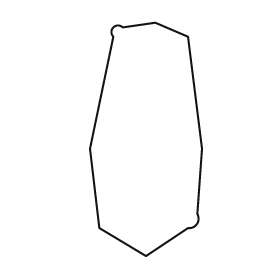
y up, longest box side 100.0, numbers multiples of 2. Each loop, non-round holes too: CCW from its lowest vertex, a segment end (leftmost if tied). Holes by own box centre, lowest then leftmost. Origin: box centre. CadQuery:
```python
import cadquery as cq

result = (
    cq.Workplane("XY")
    .moveTo(0.0, -50.0)
    .lineTo(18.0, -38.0)
    .threePointArc((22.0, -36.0), (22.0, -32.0))
    .lineTo(24.0, -4.0)
    .lineTo(18.0, 44.0)
    .lineTo(4.0, 50.0)
    .lineTo(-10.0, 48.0)
    .threePointArc((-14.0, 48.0), (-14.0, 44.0))
    .lineTo(-24.0, -4.0)
    .lineTo(-20.0, -38.0)
    .close()
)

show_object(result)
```